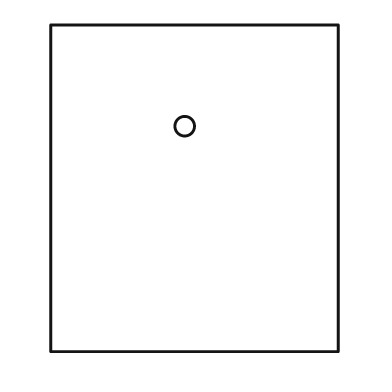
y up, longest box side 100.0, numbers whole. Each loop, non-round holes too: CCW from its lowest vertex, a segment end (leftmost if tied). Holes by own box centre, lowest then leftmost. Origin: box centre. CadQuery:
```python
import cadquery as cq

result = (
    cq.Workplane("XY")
    .moveTo(-44.0, -50.0)
    .lineTo(44.0, -50.0)
    .lineTo(44.0, 50.0)
    .lineTo(-44.0, 50.0)
    .close()
    .moveTo(-3.0, 19.0)
    .circle(3.0)
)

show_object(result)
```